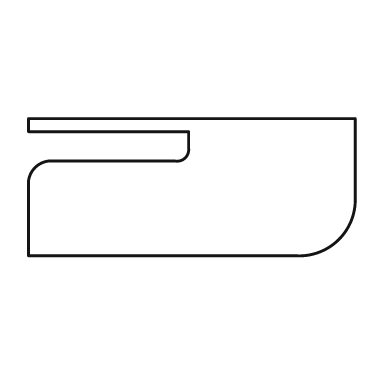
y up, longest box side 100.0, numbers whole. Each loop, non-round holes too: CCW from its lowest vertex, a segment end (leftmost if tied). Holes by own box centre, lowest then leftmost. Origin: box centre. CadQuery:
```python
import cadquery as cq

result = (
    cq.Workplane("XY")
    .moveTo(-50.0, -21.0)
    .lineTo(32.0, -21.0)
    .threePointArc((45.0, -16.0), (50.0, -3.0))
    .lineTo(50.0, 21.0)
    .lineTo(-50.0, 21.0)
    .lineTo(-50.0, 17.0)
    .lineTo(-1.0, 17.0)
    .lineTo(-1.0, 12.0)
    .threePointArc((-2.0, 9.0), (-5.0, 8.0))
    .lineTo(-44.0, 8.0)
    .threePointArc((-48.0, 6.0), (-50.0, 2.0))
    .close()
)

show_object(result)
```